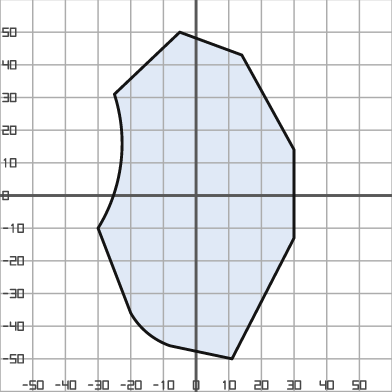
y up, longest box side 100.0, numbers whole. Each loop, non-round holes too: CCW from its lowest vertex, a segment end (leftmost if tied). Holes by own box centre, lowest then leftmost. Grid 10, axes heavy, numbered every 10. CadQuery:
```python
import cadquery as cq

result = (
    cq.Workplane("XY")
    .moveTo(11.0, -50.0)
    .lineTo(30.0, -13.0)
    .lineTo(30.0, 14.0)
    .lineTo(14.0, 43.0)
    .lineTo(-5.0, 50.0)
    .lineTo(-25.0, 31.0)
    .threePointArc((-23.0, 10.0), (-30.0, -10.0))
    .lineTo(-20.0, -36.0)
    .threePointArc((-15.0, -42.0), (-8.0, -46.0))
    .close()
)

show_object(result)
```